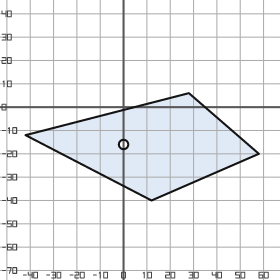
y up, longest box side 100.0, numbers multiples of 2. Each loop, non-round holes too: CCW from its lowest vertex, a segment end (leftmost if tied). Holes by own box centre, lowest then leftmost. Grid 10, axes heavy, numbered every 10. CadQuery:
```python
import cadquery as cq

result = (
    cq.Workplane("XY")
    .moveTo(12.0, -40.0)
    .lineTo(58.0, -20.0)
    .lineTo(28.0, 6.0)
    .lineTo(-42.0, -12.0)
    .close()
    .moveTo(0.0, -16.0)
    .circle(2.0)
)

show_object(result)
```